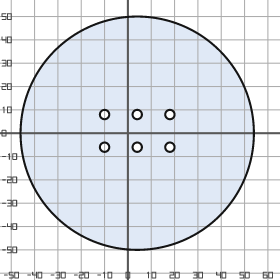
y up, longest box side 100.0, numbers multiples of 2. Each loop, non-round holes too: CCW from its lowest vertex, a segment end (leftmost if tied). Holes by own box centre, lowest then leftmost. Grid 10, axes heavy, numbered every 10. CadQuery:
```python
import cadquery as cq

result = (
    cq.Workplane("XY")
    .moveTo(4.0, 0.0)
    .circle(50.0)
    .moveTo(-10.0, -6.0)
    .circle(2.0)
    .moveTo(4.0, -6.0)
    .circle(2.0)
    .moveTo(18.0, -6.0)
    .circle(2.0)
    .moveTo(-10.0, 8.0)
    .circle(2.0)
    .moveTo(4.0, 8.0)
    .circle(2.0)
    .moveTo(18.0, 8.0)
    .circle(2.0)
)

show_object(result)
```